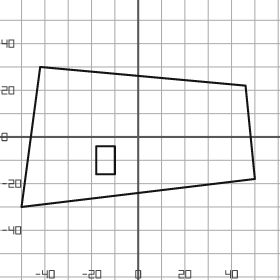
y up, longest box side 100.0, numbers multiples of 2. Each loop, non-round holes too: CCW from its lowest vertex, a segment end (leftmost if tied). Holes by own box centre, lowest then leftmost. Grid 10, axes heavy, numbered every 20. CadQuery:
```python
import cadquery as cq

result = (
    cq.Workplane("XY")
    .moveTo(-50.0, -30.0)
    .lineTo(50.0, -18.0)
    .lineTo(46.0, 22.0)
    .lineTo(-42.0, 30.0)
    .close()
    .moveTo(-18.0, -16.0)
    .lineTo(-10.0, -16.0)
    .lineTo(-10.0, -4.0)
    .lineTo(-18.0, -4.0)
    .close()
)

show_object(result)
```